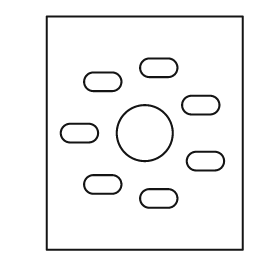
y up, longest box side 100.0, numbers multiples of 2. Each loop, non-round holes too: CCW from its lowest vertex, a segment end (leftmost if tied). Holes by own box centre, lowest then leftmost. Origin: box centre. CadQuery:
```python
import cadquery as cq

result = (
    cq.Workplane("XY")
    .moveTo(-42.0, -50.0)
    .lineTo(42.0, -50.0)
    .lineTo(42.0, 50.0)
    .lineTo(-42.0, 50.0)
    .close()
    .moveTo(2.0, -32.0)
    .lineTo(10.0, -32.0)
    .threePointArc((14.0, -28.0), (10.0, -24.0))
    .lineTo(2.0, -24.0)
    .threePointArc((-2.0, -28.0), (2.0, -32.0))
    .close()
    .moveTo(-22.0, -26.0)
    .lineTo(-14.0, -26.0)
    .threePointArc((-10.0, -22.0), (-14.0, -18.0))
    .lineTo(-22.0, -18.0)
    .threePointArc((-26.0, -22.0), (-22.0, -26.0))
    .close()
    .moveTo(22.0, -16.0)
    .lineTo(30.0, -16.0)
    .threePointArc((34.0, -12.0), (30.0, -8.0))
    .lineTo(22.0, -8.0)
    .threePointArc((18.0, -12.0), (22.0, -16.0))
    .close()
    .moveTo(-32.0, -4.0)
    .lineTo(-24.0, -4.0)
    .threePointArc((-20.0, 0.0), (-24.0, 4.0))
    .lineTo(-32.0, 4.0)
    .threePointArc((-36.0, 0.0), (-32.0, -4.0))
    .close()
    .moveTo(0.0, 0.0)
    .circle(12.0)
    .moveTo(20.0, 8.0)
    .lineTo(28.0, 8.0)
    .threePointArc((32.0, 12.0), (28.0, 16.0))
    .lineTo(20.0, 16.0)
    .threePointArc((16.0, 12.0), (20.0, 8.0))
    .close()
    .moveTo(-22.0, 18.0)
    .lineTo(-14.0, 18.0)
    .threePointArc((-10.0, 22.0), (-14.0, 26.0))
    .lineTo(-22.0, 26.0)
    .threePointArc((-26.0, 22.0), (-22.0, 18.0))
    .close()
    .moveTo(2.0, 24.0)
    .lineTo(10.0, 24.0)
    .threePointArc((14.0, 28.0), (10.0, 32.0))
    .lineTo(2.0, 32.0)
    .threePointArc((-2.0, 28.0), (2.0, 24.0))
    .close()
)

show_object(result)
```